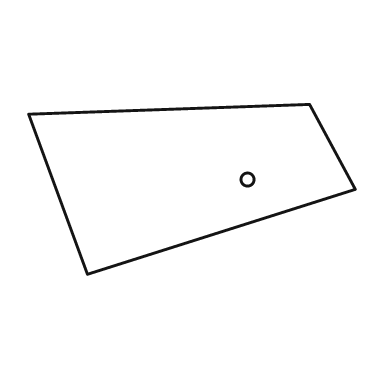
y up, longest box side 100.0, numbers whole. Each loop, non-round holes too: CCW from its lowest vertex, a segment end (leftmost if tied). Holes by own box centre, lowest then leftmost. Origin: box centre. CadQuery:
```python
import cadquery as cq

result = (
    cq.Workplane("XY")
    .moveTo(-32.0, -26.0)
    .lineTo(50.0, 0.0)
    .lineTo(36.0, 26.0)
    .lineTo(-50.0, 23.0)
    .close()
    .moveTo(17.0, 3.0)
    .circle(2.0)
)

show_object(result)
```